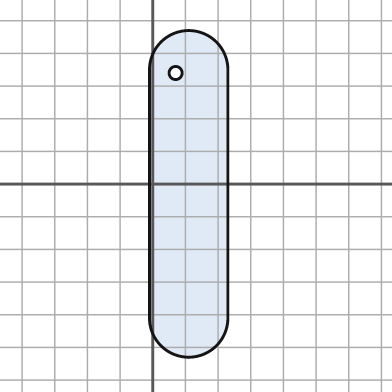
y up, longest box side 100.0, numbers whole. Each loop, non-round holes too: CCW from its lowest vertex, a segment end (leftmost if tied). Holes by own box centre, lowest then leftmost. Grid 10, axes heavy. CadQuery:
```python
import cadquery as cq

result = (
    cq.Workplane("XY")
    .moveTo(-1.0, -41.0)
    .threePointArc((11.0, -53.0), (23.0, -41.0))
    .lineTo(23.0, 35.0)
    .threePointArc((11.0, 47.0), (-1.0, 35.0))
    .close()
    .moveTo(7.0, 34.0)
    .circle(2.0)
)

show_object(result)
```